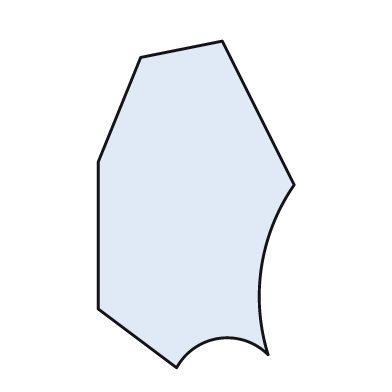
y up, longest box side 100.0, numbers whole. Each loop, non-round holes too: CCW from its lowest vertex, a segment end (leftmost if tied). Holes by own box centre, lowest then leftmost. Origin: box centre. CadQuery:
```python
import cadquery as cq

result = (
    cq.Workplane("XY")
    .moveTo(-6.0, -50.0)
    .threePointArc((7.0, -41.0), (22.0, -46.0))
    .threePointArc((20.0, -19.0), (30.0, 6.0))
    .lineTo(8.0, 50.0)
    .lineTo(-17.0, 45.0)
    .lineTo(-30.0, 13.0)
    .lineTo(-30.0, -32.0)
    .close()
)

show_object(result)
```